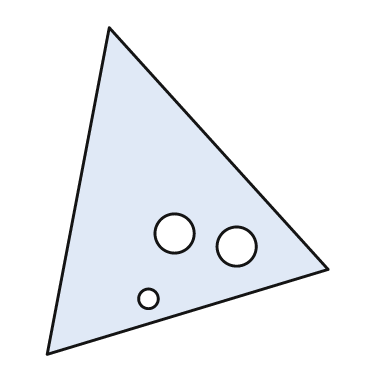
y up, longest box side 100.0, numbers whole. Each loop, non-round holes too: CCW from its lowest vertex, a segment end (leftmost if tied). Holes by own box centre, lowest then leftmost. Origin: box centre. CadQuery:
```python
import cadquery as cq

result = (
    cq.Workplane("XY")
    .moveTo(-43.0, -50.0)
    .lineTo(43.0, -24.0)
    .lineTo(-24.0, 50.0)
    .close()
    .moveTo(-12.0, -33.0)
    .circle(3.0)
    .moveTo(15.0, -17.0)
    .circle(6.0)
    .moveTo(-4.0, -13.0)
    .circle(6.0)
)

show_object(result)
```